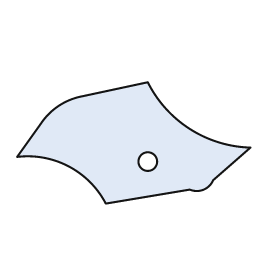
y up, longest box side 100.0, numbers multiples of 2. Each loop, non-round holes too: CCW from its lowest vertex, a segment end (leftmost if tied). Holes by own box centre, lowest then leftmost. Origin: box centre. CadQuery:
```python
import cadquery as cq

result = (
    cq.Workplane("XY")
    .moveTo(-12.0, -26.0)
    .lineTo(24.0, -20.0)
    .threePointArc((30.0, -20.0), (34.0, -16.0))
    .lineTo(50.0, -2.0)
    .threePointArc((24.0, 6.0), (6.0, 26.0))
    .lineTo(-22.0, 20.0)
    .threePointArc((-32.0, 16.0), (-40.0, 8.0))
    .lineTo(-50.0, -6.0)
    .threePointArc((-28.0, -10.0), (-12.0, -26.0))
    .close()
    .moveTo(6.0, -8.0)
    .circle(4.0)
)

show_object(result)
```